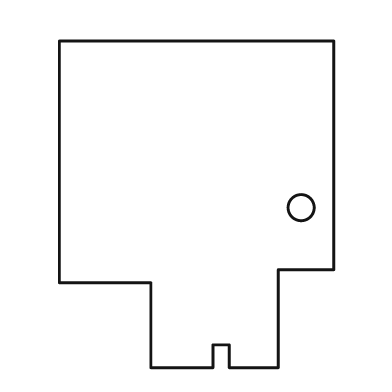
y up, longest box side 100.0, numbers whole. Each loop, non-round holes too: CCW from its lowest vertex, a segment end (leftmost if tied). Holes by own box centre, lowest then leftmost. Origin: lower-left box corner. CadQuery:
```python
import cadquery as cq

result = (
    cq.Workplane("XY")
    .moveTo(28.0, 0.0)
    .lineTo(47.0, 0.0)
    .lineTo(47.0, 7.0)
    .lineTo(52.0, 7.0)
    .lineTo(52.0, 0.0)
    .lineTo(67.0, 0.0)
    .lineTo(67.0, 30.0)
    .lineTo(84.0, 30.0)
    .lineTo(84.0, 100.0)
    .lineTo(0.0, 100.0)
    .lineTo(0.0, 26.0)
    .lineTo(28.0, 26.0)
    .close()
    .moveTo(74.0, 49.0)
    .circle(4.0)
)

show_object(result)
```